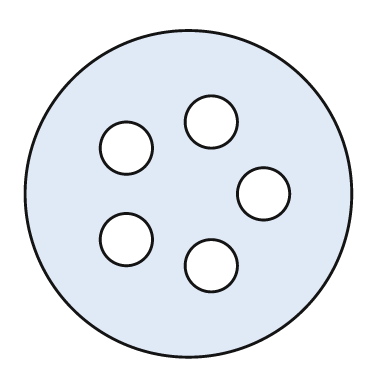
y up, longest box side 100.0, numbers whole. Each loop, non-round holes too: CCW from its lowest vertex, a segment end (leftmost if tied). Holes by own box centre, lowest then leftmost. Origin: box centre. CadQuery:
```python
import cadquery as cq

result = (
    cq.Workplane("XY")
    .moveTo(0.0, 0.0)
    .circle(50.0)
    .moveTo(7.0, -22.0)
    .circle(8.0)
    .moveTo(-19.0, -14.0)
    .circle(8.0)
    .moveTo(23.0, 0.0)
    .circle(8.0)
    .moveTo(-19.0, 14.0)
    .circle(8.0)
    .moveTo(7.0, 22.0)
    .circle(8.0)
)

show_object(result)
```